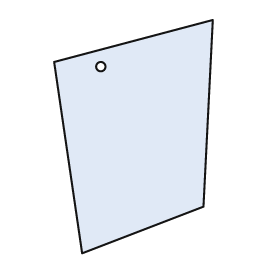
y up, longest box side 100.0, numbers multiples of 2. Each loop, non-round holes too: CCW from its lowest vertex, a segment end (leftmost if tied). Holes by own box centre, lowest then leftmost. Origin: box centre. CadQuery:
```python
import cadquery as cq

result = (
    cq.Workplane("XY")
    .moveTo(-22.0, -50.0)
    .lineTo(30.0, -30.0)
    .lineTo(34.0, 50.0)
    .lineTo(-34.0, 32.0)
    .close()
    .moveTo(-14.0, 30.0)
    .circle(2.0)
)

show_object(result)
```